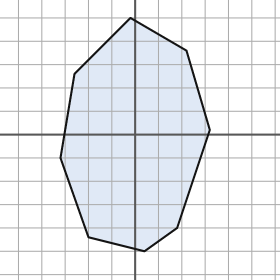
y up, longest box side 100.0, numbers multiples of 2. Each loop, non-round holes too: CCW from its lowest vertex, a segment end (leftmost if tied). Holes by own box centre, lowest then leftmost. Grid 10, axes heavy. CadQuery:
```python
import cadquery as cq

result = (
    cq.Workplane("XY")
    .moveTo(4.0, -50.0)
    .lineTo(18.0, -40.0)
    .lineTo(32.0, 2.0)
    .lineTo(22.0, 36.0)
    .lineTo(-2.0, 50.0)
    .lineTo(-26.0, 26.0)
    .lineTo(-32.0, -10.0)
    .lineTo(-20.0, -44.0)
    .close()
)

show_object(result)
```